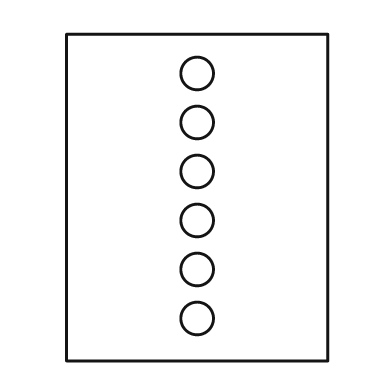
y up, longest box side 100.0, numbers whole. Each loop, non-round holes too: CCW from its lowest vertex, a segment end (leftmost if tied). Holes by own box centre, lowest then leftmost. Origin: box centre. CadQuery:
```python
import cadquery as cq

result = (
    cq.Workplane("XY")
    .moveTo(-40.0, -50.0)
    .lineTo(40.0, -50.0)
    .lineTo(40.0, 50.0)
    .lineTo(-40.0, 50.0)
    .close()
    .moveTo(0.0, -37.0)
    .circle(5.0)
    .moveTo(0.0, -22.0)
    .circle(5.0)
    .moveTo(0.0, -7.0)
    .circle(5.0)
    .moveTo(0.0, 8.0)
    .circle(5.0)
    .moveTo(0.0, 23.0)
    .circle(5.0)
    .moveTo(0.0, 38.0)
    .circle(5.0)
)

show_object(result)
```